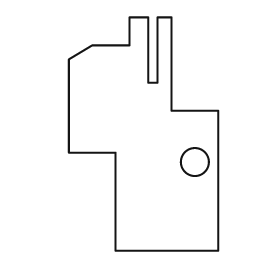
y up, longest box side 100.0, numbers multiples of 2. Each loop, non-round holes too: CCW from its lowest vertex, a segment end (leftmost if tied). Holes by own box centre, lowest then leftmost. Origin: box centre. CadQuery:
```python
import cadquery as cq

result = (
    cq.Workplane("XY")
    .moveTo(-12.0, -50.0)
    .lineTo(32.0, -50.0)
    .lineTo(32.0, 10.0)
    .lineTo(12.0, 10.0)
    .lineTo(12.0, 50.0)
    .lineTo(6.0, 50.0)
    .lineTo(6.0, 22.0)
    .lineTo(2.0, 22.0)
    .lineTo(2.0, 50.0)
    .lineTo(-6.0, 50.0)
    .lineTo(-6.0, 38.0)
    .lineTo(-22.0, 38.0)
    .lineTo(-32.0, 32.0)
    .lineTo(-32.0, -8.0)
    .lineTo(-12.0, -8.0)
    .close()
    .moveTo(22.0, -12.0)
    .circle(6.0)
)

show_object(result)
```